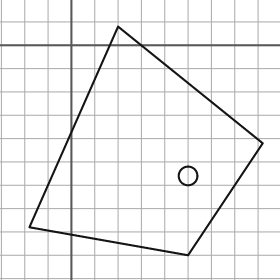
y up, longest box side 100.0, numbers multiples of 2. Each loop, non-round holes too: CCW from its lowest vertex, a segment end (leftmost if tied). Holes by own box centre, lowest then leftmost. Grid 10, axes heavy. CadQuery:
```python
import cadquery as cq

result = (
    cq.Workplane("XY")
    .moveTo(50.0, -90.0)
    .lineTo(82.0, -42.0)
    .lineTo(20.0, 8.0)
    .lineTo(-18.0, -78.0)
    .close()
    .moveTo(50.0, -56.0)
    .circle(4.0)
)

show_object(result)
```